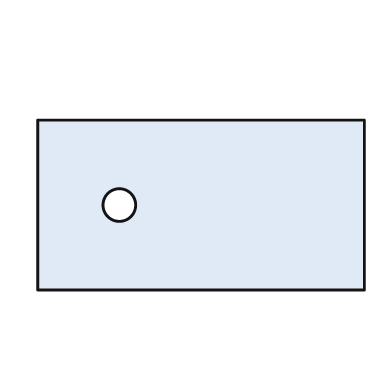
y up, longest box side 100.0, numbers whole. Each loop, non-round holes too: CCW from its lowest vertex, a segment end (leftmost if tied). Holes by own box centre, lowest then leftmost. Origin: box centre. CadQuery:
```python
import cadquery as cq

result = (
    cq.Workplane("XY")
    .moveTo(-50.0, -26.0)
    .lineTo(50.0, -26.0)
    .lineTo(50.0, 26.0)
    .lineTo(-50.0, 26.0)
    .close()
    .moveTo(-25.0, 0.0)
    .circle(5.0)
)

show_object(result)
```